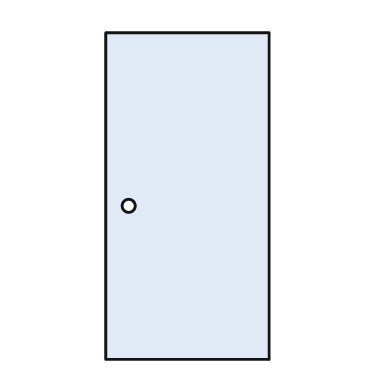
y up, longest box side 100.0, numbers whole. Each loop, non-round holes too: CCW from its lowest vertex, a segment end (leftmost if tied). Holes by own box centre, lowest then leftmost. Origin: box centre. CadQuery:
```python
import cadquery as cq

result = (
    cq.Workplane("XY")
    .moveTo(-25.0, -50.0)
    .lineTo(25.0, -50.0)
    .lineTo(25.0, 50.0)
    .lineTo(-25.0, 50.0)
    .close()
    .moveTo(-18.0, -3.0)
    .circle(2.0)
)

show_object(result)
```